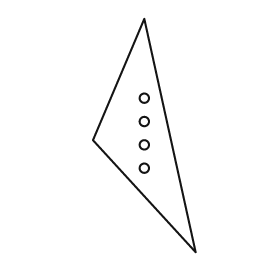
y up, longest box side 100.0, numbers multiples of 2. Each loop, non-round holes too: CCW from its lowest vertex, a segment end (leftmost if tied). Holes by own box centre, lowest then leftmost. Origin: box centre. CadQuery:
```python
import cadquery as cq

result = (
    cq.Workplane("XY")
    .moveTo(22.0, -50.0)
    .lineTo(0.0, 50.0)
    .lineTo(-22.0, -2.0)
    .close()
    .moveTo(0.0, -14.0)
    .circle(2.0)
    .moveTo(0.0, -4.0)
    .circle(2.0)
    .moveTo(0.0, 6.0)
    .circle(2.0)
    .moveTo(0.0, 16.0)
    .circle(2.0)
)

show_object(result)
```